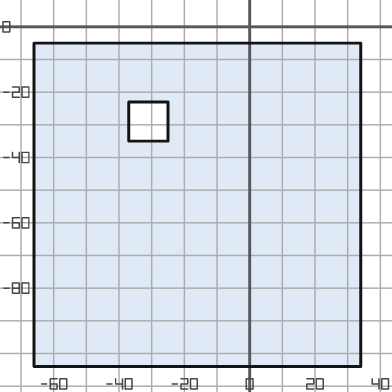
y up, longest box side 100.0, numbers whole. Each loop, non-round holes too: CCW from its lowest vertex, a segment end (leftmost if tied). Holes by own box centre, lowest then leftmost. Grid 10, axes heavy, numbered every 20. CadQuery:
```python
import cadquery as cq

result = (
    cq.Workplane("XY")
    .moveTo(-66.0, -104.0)
    .lineTo(34.0, -104.0)
    .lineTo(34.0, -5.0)
    .lineTo(-66.0, -5.0)
    .close()
    .moveTo(-37.0, -35.0)
    .lineTo(-25.0, -35.0)
    .lineTo(-25.0, -23.0)
    .lineTo(-37.0, -23.0)
    .close()
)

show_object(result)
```